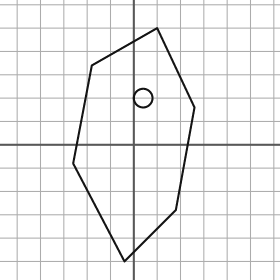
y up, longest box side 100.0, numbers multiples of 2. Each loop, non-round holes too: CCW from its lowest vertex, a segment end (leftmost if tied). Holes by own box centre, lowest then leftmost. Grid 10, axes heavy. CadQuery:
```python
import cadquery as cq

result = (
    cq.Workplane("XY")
    .moveTo(-4.0, -50.0)
    .lineTo(18.0, -28.0)
    .lineTo(26.0, 16.0)
    .lineTo(10.0, 50.0)
    .lineTo(-18.0, 34.0)
    .lineTo(-26.0, -8.0)
    .close()
    .moveTo(4.0, 20.0)
    .circle(4.0)
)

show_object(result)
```